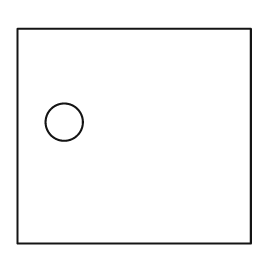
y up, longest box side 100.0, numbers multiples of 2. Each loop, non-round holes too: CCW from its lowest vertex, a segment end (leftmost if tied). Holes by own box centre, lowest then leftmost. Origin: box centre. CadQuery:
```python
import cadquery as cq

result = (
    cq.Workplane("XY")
    .moveTo(-50.0, -46.0)
    .lineTo(50.0, -46.0)
    .lineTo(50.0, 46.0)
    .lineTo(-50.0, 46.0)
    .close()
    .moveTo(-30.0, 6.0)
    .circle(8.0)
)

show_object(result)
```